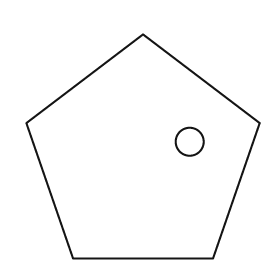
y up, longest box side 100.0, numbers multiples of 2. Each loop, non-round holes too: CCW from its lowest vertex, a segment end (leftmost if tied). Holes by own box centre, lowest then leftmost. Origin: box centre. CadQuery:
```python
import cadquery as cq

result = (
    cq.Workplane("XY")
    .moveTo(-30.0, -48.0)
    .lineTo(30.0, -48.0)
    .lineTo(50.0, 10.0)
    .lineTo(0.0, 48.0)
    .lineTo(-50.0, 10.0)
    .close()
    .moveTo(20.0, 2.0)
    .circle(6.0)
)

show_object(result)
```